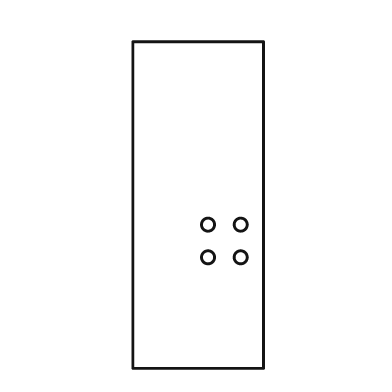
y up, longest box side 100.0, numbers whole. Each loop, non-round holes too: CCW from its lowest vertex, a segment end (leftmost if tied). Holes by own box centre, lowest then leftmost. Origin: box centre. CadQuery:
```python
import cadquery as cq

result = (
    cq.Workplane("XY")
    .moveTo(-20.0, -50.0)
    .lineTo(20.0, -50.0)
    .lineTo(20.0, 50.0)
    .lineTo(-20.0, 50.0)
    .close()
    .moveTo(3.0, -16.0)
    .circle(2.0)
    .moveTo(13.0, -16.0)
    .circle(2.0)
    .moveTo(3.0, -6.0)
    .circle(2.0)
    .moveTo(13.0, -6.0)
    .circle(2.0)
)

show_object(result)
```